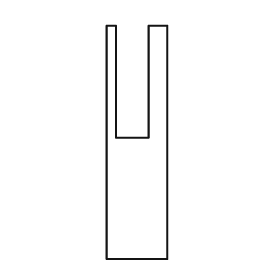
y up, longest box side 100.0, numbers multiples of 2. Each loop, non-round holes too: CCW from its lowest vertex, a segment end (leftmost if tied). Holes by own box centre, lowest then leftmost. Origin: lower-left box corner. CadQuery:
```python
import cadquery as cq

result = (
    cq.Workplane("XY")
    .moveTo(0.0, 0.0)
    .lineTo(26.0, 0.0)
    .lineTo(26.0, 100.0)
    .lineTo(18.0, 100.0)
    .lineTo(18.0, 52.0)
    .lineTo(4.0, 52.0)
    .lineTo(4.0, 100.0)
    .lineTo(0.0, 100.0)
    .close()
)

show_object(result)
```